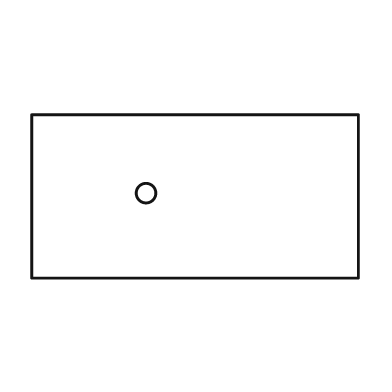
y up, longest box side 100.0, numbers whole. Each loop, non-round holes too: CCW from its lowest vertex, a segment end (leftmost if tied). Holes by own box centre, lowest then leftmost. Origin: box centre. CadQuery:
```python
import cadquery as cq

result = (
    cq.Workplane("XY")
    .moveTo(-50.0, -25.0)
    .lineTo(50.0, -25.0)
    .lineTo(50.0, 25.0)
    .lineTo(-50.0, 25.0)
    .close()
    .moveTo(-15.0, 1.0)
    .circle(3.0)
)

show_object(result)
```